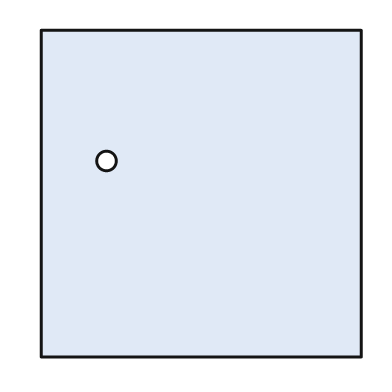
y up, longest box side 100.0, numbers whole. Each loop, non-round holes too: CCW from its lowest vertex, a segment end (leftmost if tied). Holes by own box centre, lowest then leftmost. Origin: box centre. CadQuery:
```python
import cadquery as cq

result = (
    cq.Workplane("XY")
    .moveTo(-49.0, -50.0)
    .lineTo(49.0, -50.0)
    .lineTo(49.0, 50.0)
    .lineTo(-49.0, 50.0)
    .close()
    .moveTo(-29.0, 10.0)
    .circle(3.0)
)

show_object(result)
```